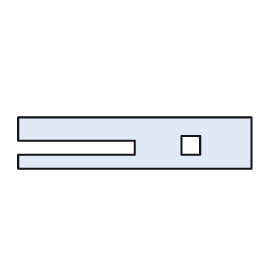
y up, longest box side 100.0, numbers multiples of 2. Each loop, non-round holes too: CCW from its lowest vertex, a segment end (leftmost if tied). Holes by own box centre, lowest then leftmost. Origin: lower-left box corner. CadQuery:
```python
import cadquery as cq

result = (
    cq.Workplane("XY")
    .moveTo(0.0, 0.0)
    .lineTo(100.0, 0.0)
    .lineTo(100.0, 22.0)
    .lineTo(0.0, 22.0)
    .lineTo(0.0, 12.0)
    .lineTo(50.0, 12.0)
    .lineTo(50.0, 6.0)
    .lineTo(0.0, 6.0)
    .close()
    .moveTo(70.0, 6.0)
    .lineTo(78.0, 6.0)
    .lineTo(78.0, 14.0)
    .lineTo(70.0, 14.0)
    .close()
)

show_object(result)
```